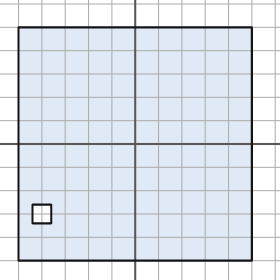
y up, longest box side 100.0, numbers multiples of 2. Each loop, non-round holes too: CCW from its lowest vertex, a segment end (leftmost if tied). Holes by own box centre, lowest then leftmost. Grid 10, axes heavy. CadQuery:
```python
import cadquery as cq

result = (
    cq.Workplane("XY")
    .moveTo(-50.0, -50.0)
    .lineTo(50.0, -50.0)
    .lineTo(50.0, 50.0)
    .lineTo(-50.0, 50.0)
    .close()
    .moveTo(-44.0, -34.0)
    .lineTo(-36.0, -34.0)
    .lineTo(-36.0, -26.0)
    .lineTo(-44.0, -26.0)
    .close()
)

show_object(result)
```